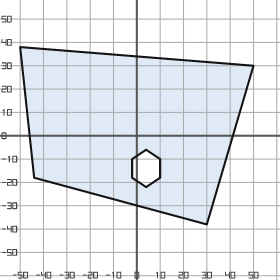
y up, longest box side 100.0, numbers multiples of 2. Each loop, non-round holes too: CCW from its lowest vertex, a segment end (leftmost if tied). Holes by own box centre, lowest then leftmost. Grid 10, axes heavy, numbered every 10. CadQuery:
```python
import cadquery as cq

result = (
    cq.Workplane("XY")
    .moveTo(30.0, -38.0)
    .lineTo(50.0, 30.0)
    .lineTo(-50.0, 38.0)
    .lineTo(-44.0, -18.0)
    .close()
    .moveTo(4.0, -22.0)
    .lineTo(10.0, -18.0)
    .lineTo(10.0, -10.0)
    .lineTo(4.0, -6.0)
    .lineTo(-2.0, -10.0)
    .lineTo(-2.0, -18.0)
    .close()
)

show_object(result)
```